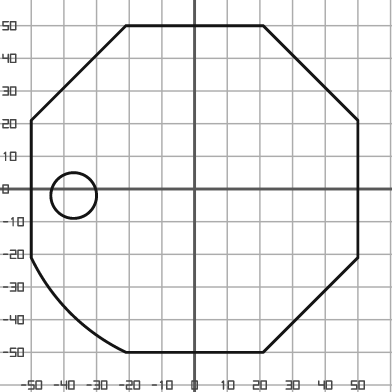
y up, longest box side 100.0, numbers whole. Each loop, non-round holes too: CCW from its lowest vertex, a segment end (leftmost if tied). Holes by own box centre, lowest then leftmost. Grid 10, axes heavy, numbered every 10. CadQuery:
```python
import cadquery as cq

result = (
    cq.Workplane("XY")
    .moveTo(-21.0, -50.0)
    .lineTo(21.0, -50.0)
    .lineTo(50.0, -21.0)
    .lineTo(50.0, 21.0)
    .lineTo(21.0, 50.0)
    .lineTo(-21.0, 50.0)
    .lineTo(-50.0, 21.0)
    .lineTo(-50.0, -21.0)
    .threePointArc((-38.0, -38.0), (-21.0, -50.0))
    .close()
    .moveTo(-37.0, -2.0)
    .circle(7.0)
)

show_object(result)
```